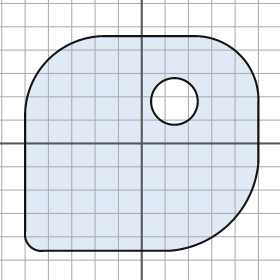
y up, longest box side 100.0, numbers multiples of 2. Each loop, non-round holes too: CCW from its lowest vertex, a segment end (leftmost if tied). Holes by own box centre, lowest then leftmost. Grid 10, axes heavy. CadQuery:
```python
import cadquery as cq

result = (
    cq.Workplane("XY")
    .moveTo(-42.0, -46.0)
    .lineTo(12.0, -46.0)
    .threePointArc((38.0, -34.0), (50.0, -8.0))
    .lineTo(50.0, 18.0)
    .threePointArc((42.0, 38.0), (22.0, 46.0))
    .lineTo(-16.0, 46.0)
    .threePointArc((-40.0, 36.0), (-50.0, 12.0))
    .lineTo(-50.0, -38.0)
    .threePointArc((-48.0, -44.0), (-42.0, -46.0))
    .close()
    .moveTo(14.0, 18.0)
    .circle(10.0)
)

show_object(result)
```